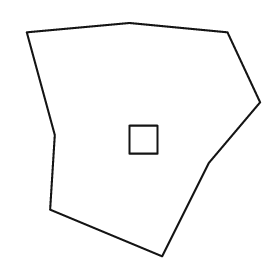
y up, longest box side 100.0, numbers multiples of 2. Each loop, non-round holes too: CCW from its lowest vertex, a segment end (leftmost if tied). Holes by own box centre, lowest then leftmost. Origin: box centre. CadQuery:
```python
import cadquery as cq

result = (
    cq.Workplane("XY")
    .moveTo(8.0, -50.0)
    .lineTo(28.0, -10.0)
    .lineTo(50.0, 16.0)
    .lineTo(36.0, 46.0)
    .lineTo(-6.0, 50.0)
    .lineTo(-50.0, 46.0)
    .lineTo(-38.0, 2.0)
    .lineTo(-40.0, -30.0)
    .close()
    .moveTo(-6.0, -6.0)
    .lineTo(6.0, -6.0)
    .lineTo(6.0, 6.0)
    .lineTo(-6.0, 6.0)
    .close()
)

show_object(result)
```